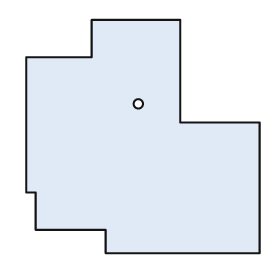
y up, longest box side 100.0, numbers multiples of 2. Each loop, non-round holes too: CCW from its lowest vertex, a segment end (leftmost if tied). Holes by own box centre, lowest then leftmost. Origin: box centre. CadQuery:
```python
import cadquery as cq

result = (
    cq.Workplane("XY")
    .moveTo(-16.0, -50.0)
    .lineTo(50.0, -50.0)
    .lineTo(50.0, 6.0)
    .lineTo(16.0, 6.0)
    .lineTo(16.0, 50.0)
    .lineTo(-22.0, 50.0)
    .lineTo(-22.0, 34.0)
    .lineTo(-50.0, 34.0)
    .lineTo(-50.0, -24.0)
    .lineTo(-46.0, -24.0)
    .lineTo(-46.0, -40.0)
    .lineTo(-16.0, -40.0)
    .close()
    .moveTo(-2.0, 14.0)
    .circle(2.0)
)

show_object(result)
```